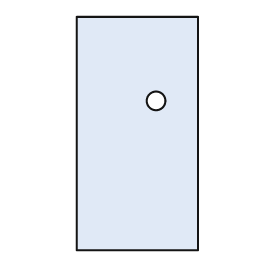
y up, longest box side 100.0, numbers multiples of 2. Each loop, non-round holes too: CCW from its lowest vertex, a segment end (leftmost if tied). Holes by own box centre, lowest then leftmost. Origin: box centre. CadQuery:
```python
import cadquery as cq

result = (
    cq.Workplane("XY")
    .moveTo(-26.0, -50.0)
    .lineTo(26.0, -50.0)
    .lineTo(26.0, 50.0)
    .lineTo(-26.0, 50.0)
    .close()
    .moveTo(8.0, 14.0)
    .circle(4.0)
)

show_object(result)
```